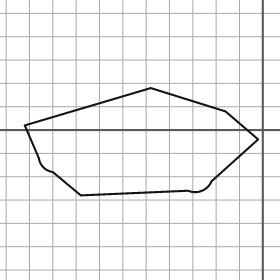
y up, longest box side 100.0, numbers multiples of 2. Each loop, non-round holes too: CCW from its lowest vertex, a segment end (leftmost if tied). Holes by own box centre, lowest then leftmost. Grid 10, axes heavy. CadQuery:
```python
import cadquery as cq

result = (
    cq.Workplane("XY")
    .moveTo(-78.0, -28.0)
    .lineTo(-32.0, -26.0)
    .threePointArc((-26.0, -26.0), (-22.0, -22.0))
    .lineTo(-2.0, -4.0)
    .lineTo(-16.0, 8.0)
    .lineTo(-48.0, 18.0)
    .lineTo(-102.0, 2.0)
    .lineTo(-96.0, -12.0)
    .threePointArc((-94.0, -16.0), (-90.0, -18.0))
    .close()
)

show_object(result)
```